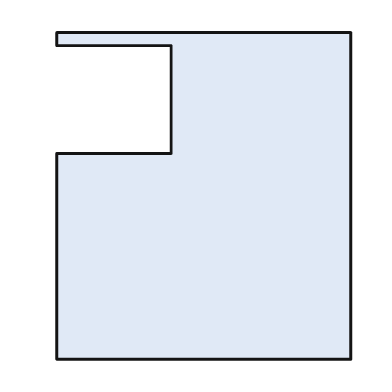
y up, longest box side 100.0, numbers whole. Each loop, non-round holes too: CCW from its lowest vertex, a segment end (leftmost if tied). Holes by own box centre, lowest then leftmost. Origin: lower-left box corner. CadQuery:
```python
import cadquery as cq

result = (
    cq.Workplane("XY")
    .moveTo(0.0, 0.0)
    .lineTo(90.0, 0.0)
    .lineTo(90.0, 100.0)
    .lineTo(0.0, 100.0)
    .lineTo(0.0, 96.0)
    .lineTo(35.0, 96.0)
    .lineTo(35.0, 63.0)
    .lineTo(0.0, 63.0)
    .close()
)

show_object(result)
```